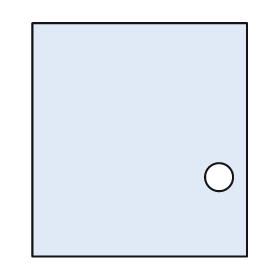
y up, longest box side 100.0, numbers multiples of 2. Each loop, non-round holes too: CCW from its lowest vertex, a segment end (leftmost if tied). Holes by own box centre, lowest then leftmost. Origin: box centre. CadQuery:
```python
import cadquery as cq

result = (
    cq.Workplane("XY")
    .moveTo(-46.0, -50.0)
    .lineTo(46.0, -50.0)
    .lineTo(46.0, 50.0)
    .lineTo(-46.0, 50.0)
    .close()
    .moveTo(34.0, -16.0)
    .circle(6.0)
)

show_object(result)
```